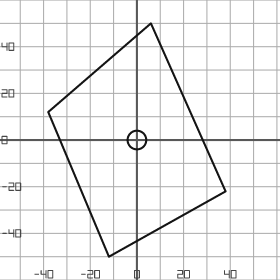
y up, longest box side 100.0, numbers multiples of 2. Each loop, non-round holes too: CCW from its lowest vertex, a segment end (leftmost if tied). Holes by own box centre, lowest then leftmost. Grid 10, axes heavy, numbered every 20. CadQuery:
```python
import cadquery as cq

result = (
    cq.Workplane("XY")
    .moveTo(-12.0, -50.0)
    .lineTo(38.0, -22.0)
    .lineTo(6.0, 50.0)
    .lineTo(-38.0, 12.0)
    .close()
    .moveTo(0.0, 0.0)
    .circle(4.0)
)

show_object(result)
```